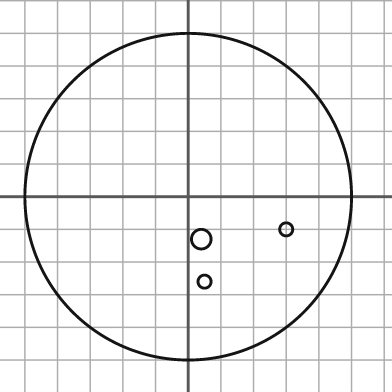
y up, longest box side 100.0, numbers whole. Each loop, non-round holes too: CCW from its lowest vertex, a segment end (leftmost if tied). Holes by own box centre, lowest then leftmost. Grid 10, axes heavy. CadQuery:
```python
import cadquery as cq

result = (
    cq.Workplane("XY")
    .moveTo(0.0, 0.0)
    .circle(50.0)
    .moveTo(5.0, -26.0)
    .circle(2.0)
    .moveTo(4.0, -13.0)
    .circle(3.0)
    .moveTo(30.0, -10.0)
    .circle(2.0)
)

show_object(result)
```